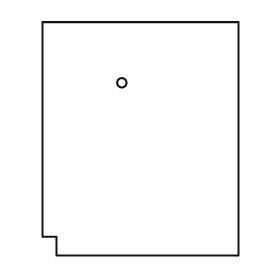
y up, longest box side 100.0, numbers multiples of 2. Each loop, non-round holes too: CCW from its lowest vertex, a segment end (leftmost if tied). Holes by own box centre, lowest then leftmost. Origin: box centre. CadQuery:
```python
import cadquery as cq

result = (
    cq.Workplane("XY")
    .moveTo(-36.0, -50.0)
    .lineTo(42.0, -50.0)
    .lineTo(42.0, 50.0)
    .lineTo(-42.0, 50.0)
    .lineTo(-42.0, -42.0)
    .lineTo(-36.0, -42.0)
    .close()
    .moveTo(-8.0, 24.0)
    .circle(2.0)
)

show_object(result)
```